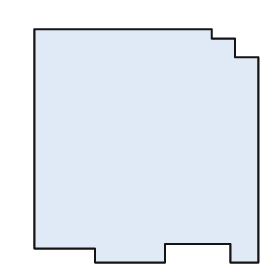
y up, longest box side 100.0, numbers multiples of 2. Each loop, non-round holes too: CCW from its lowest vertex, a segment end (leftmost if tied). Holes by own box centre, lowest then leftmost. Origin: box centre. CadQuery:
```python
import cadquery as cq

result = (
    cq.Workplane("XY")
    .moveTo(-22.0, -50.0)
    .lineTo(8.0, -50.0)
    .lineTo(8.0, -42.0)
    .lineTo(36.0, -42.0)
    .lineTo(36.0, -50.0)
    .lineTo(48.0, -50.0)
    .lineTo(48.0, 38.0)
    .lineTo(38.0, 38.0)
    .lineTo(38.0, 46.0)
    .lineTo(28.0, 46.0)
    .lineTo(28.0, 50.0)
    .lineTo(-48.0, 50.0)
    .lineTo(-48.0, -44.0)
    .lineTo(-22.0, -44.0)
    .close()
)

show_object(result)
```